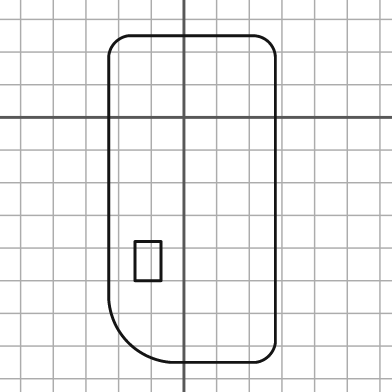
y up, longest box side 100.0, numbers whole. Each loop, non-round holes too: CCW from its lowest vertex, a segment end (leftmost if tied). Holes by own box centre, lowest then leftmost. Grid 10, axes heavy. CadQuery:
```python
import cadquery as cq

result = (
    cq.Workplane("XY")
    .moveTo(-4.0, -75.0)
    .lineTo(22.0, -75.0)
    .threePointArc((26.0, -73.0), (28.0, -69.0))
    .lineTo(28.0, 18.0)
    .threePointArc((26.0, 23.0), (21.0, 25.0))
    .lineTo(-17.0, 25.0)
    .threePointArc((-21.0, 23.0), (-23.0, 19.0))
    .lineTo(-23.0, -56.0)
    .threePointArc((-17.0, -69.0), (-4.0, -75.0))
    .close()
    .moveTo(-15.0, -50.0)
    .lineTo(-7.0, -50.0)
    .lineTo(-7.0, -38.0)
    .lineTo(-15.0, -38.0)
    .close()
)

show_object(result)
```